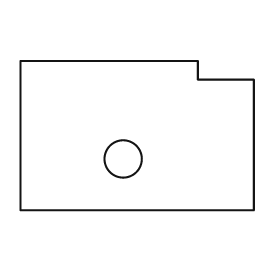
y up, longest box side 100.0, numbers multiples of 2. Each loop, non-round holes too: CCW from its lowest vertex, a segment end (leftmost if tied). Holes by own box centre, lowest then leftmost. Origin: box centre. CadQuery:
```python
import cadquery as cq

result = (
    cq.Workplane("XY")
    .moveTo(-50.0, -32.0)
    .lineTo(50.0, -32.0)
    .lineTo(50.0, 24.0)
    .lineTo(26.0, 24.0)
    .lineTo(26.0, 32.0)
    .lineTo(-50.0, 32.0)
    .close()
    .moveTo(-6.0, -10.0)
    .circle(8.0)
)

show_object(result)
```